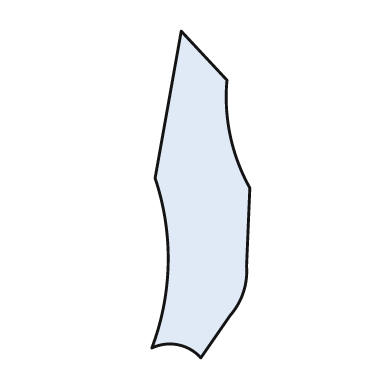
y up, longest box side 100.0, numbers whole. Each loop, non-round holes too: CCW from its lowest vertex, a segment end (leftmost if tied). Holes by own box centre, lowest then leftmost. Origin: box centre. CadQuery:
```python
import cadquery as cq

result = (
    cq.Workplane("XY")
    .moveTo(0.0, -50.0)
    .lineTo(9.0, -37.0)
    .threePointArc((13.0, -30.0), (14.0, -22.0))
    .lineTo(15.0, 2.0)
    .threePointArc((9.0, 18.0), (8.0, 35.0))
    .lineTo(-6.0, 50.0)
    .lineTo(-14.0, 5.0)
    .threePointArc((-10.0, -21.0), (-15.0, -47.0))
    .threePointArc((-7.0, -46.0), (0.0, -50.0))
    .close()
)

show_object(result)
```